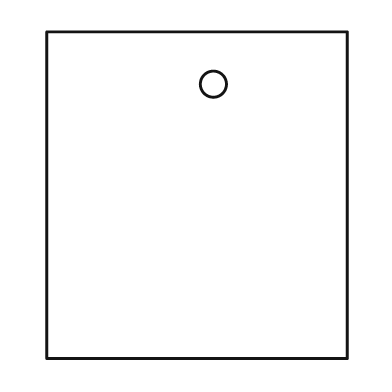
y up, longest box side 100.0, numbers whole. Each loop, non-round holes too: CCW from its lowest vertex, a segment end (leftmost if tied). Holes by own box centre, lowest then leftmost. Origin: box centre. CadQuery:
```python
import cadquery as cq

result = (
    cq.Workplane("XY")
    .moveTo(-46.0, -50.0)
    .lineTo(46.0, -50.0)
    .lineTo(46.0, 50.0)
    .lineTo(-46.0, 50.0)
    .close()
    .moveTo(5.0, 34.0)
    .circle(4.0)
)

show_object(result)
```